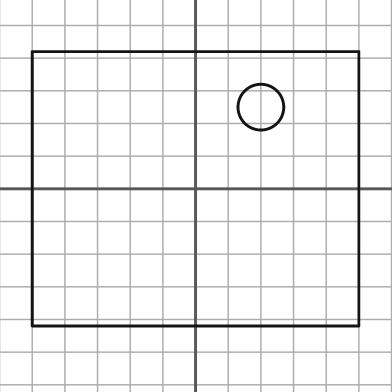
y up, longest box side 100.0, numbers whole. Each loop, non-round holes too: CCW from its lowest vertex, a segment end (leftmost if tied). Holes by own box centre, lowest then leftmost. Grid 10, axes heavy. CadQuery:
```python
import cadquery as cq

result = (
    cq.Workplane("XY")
    .moveTo(-50.0, -42.0)
    .lineTo(50.0, -42.0)
    .lineTo(50.0, 42.0)
    .lineTo(-50.0, 42.0)
    .close()
    .moveTo(20.0, 25.0)
    .circle(7.0)
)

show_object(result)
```